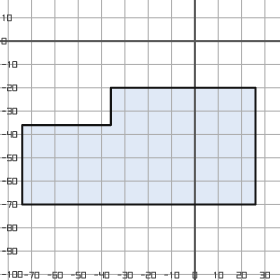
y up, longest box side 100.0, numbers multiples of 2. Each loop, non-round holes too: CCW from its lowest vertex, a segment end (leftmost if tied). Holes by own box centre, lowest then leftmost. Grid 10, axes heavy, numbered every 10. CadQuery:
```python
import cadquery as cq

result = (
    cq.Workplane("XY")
    .moveTo(-74.0, -70.0)
    .lineTo(26.0, -70.0)
    .lineTo(26.0, -20.0)
    .lineTo(-36.0, -20.0)
    .lineTo(-36.0, -36.0)
    .lineTo(-74.0, -36.0)
    .close()
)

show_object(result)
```